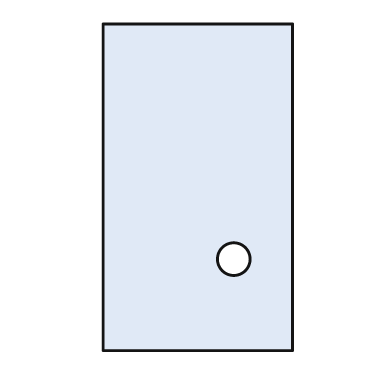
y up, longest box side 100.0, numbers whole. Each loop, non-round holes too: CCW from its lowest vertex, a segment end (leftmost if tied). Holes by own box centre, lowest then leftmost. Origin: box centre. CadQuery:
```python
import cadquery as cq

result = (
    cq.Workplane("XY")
    .moveTo(-29.0, -50.0)
    .lineTo(29.0, -50.0)
    .lineTo(29.0, 50.0)
    .lineTo(-29.0, 50.0)
    .close()
    .moveTo(11.0, -22.0)
    .circle(5.0)
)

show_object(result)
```